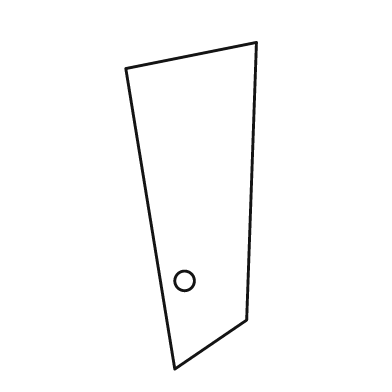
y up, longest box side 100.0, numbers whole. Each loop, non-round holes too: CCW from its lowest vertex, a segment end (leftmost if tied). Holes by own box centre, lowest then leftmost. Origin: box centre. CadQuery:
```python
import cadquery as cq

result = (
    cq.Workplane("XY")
    .moveTo(-5.0, -50.0)
    .lineTo(17.0, -35.0)
    .lineTo(20.0, 50.0)
    .lineTo(-20.0, 42.0)
    .close()
    .moveTo(-2.0, -23.0)
    .circle(3.0)
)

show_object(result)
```